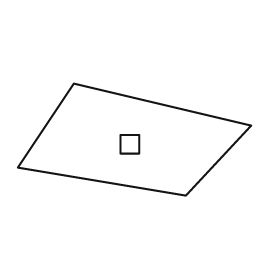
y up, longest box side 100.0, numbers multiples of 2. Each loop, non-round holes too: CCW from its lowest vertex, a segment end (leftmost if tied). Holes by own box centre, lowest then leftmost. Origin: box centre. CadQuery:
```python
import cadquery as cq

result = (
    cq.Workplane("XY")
    .moveTo(22.0, -24.0)
    .lineTo(50.0, 6.0)
    .lineTo(-26.0, 24.0)
    .lineTo(-50.0, -12.0)
    .close()
    .moveTo(-6.0, -6.0)
    .lineTo(2.0, -6.0)
    .lineTo(2.0, 2.0)
    .lineTo(-6.0, 2.0)
    .close()
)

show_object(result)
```